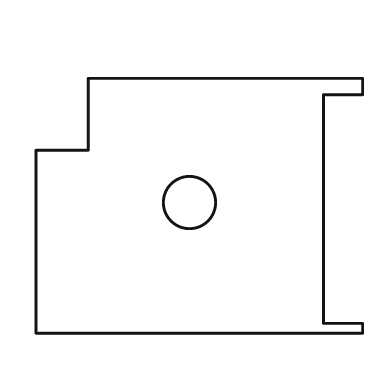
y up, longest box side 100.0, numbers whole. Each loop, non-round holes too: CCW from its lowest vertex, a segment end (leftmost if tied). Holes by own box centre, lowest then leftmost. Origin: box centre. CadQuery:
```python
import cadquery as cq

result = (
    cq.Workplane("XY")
    .moveTo(-50.0, -39.0)
    .lineTo(50.0, -39.0)
    .lineTo(50.0, -36.0)
    .lineTo(38.0, -36.0)
    .lineTo(38.0, 34.0)
    .lineTo(50.0, 34.0)
    .lineTo(50.0, 39.0)
    .lineTo(-34.0, 39.0)
    .lineTo(-34.0, 17.0)
    .lineTo(-50.0, 17.0)
    .close()
    .moveTo(-3.0, 1.0)
    .circle(8.0)
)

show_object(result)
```